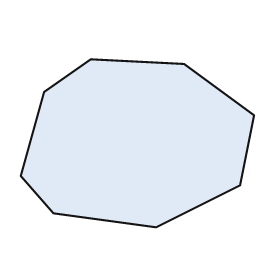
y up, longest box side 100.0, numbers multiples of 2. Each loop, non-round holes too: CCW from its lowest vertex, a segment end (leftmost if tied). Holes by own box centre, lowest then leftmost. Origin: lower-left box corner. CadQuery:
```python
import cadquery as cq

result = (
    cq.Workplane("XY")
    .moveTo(58.0, 0.0)
    .lineTo(94.0, 18.0)
    .lineTo(100.0, 48.0)
    .lineTo(70.0, 70.0)
    .lineTo(30.0, 72.0)
    .lineTo(10.0, 58.0)
    .lineTo(0.0, 22.0)
    .lineTo(14.0, 6.0)
    .close()
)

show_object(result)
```